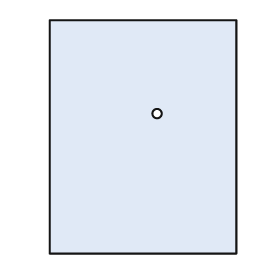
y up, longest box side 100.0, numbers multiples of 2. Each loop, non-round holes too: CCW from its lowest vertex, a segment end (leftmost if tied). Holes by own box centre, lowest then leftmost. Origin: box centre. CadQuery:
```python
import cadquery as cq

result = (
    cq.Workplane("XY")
    .moveTo(-40.0, -50.0)
    .lineTo(40.0, -50.0)
    .lineTo(40.0, 50.0)
    .lineTo(-40.0, 50.0)
    .close()
    .moveTo(6.0, 10.0)
    .circle(2.0)
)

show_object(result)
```